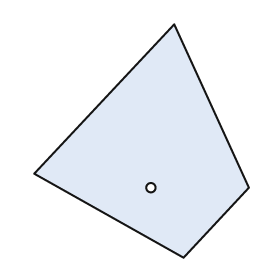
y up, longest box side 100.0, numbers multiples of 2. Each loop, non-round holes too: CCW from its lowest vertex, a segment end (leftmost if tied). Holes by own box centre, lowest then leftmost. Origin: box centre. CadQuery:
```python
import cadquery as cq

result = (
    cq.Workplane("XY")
    .moveTo(18.0, -50.0)
    .lineTo(46.0, -20.0)
    .lineTo(14.0, 50.0)
    .lineTo(-46.0, -14.0)
    .close()
    .moveTo(4.0, -20.0)
    .circle(2.0)
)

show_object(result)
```